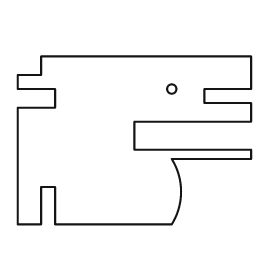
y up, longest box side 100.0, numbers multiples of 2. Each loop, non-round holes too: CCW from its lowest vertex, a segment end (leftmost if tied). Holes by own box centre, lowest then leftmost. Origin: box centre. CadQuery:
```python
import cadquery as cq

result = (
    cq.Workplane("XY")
    .moveTo(-50.0, -36.0)
    .lineTo(-40.0, -36.0)
    .lineTo(-40.0, -20.0)
    .lineTo(-34.0, -20.0)
    .lineTo(-34.0, -36.0)
    .lineTo(16.0, -36.0)
    .threePointArc((20.0, -22.0), (16.0, -8.0))
    .lineTo(50.0, -8.0)
    .lineTo(50.0, -4.0)
    .lineTo(0.0, -4.0)
    .lineTo(0.0, 8.0)
    .lineTo(50.0, 8.0)
    .lineTo(50.0, 16.0)
    .lineTo(30.0, 16.0)
    .lineTo(30.0, 22.0)
    .lineTo(50.0, 22.0)
    .lineTo(50.0, 36.0)
    .lineTo(-40.0, 36.0)
    .lineTo(-40.0, 28.0)
    .lineTo(-50.0, 28.0)
    .lineTo(-50.0, 22.0)
    .lineTo(-34.0, 22.0)
    .lineTo(-34.0, 14.0)
    .lineTo(-50.0, 14.0)
    .close()
    .moveTo(16.0, 22.0)
    .circle(2.0)
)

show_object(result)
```